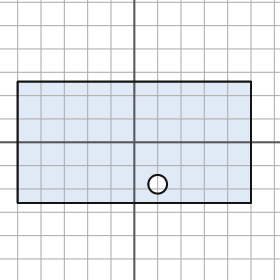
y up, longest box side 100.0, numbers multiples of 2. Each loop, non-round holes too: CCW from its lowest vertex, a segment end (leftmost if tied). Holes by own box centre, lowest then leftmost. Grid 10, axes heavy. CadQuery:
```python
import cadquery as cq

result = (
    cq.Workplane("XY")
    .moveTo(-50.0, -26.0)
    .lineTo(50.0, -26.0)
    .lineTo(50.0, 26.0)
    .lineTo(-50.0, 26.0)
    .close()
    .moveTo(10.0, -18.0)
    .circle(4.0)
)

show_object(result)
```